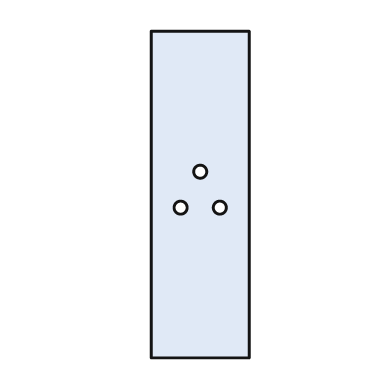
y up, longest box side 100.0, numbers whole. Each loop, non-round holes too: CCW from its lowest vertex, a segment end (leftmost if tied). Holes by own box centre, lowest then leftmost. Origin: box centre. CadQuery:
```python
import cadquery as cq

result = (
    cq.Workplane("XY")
    .moveTo(-15.0, -50.0)
    .lineTo(15.0, -50.0)
    .lineTo(15.0, 50.0)
    .lineTo(-15.0, 50.0)
    .close()
    .moveTo(-6.0, -4.0)
    .circle(2.0)
    .moveTo(6.0, -4.0)
    .circle(2.0)
    .moveTo(0.0, 7.0)
    .circle(2.0)
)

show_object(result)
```